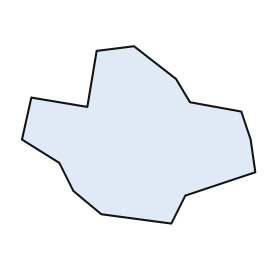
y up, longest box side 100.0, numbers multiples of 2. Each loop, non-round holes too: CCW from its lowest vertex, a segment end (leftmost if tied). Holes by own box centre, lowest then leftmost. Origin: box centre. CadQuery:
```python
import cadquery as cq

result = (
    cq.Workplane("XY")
    .moveTo(14.0, -38.0)
    .lineTo(20.0, -26.0)
    .lineTo(50.0, -16.0)
    .lineTo(48.0, -2.0)
    .lineTo(44.0, 10.0)
    .lineTo(22.0, 14.0)
    .lineTo(16.0, 24.0)
    .lineTo(-2.0, 38.0)
    .lineTo(-18.0, 36.0)
    .lineTo(-22.0, 12.0)
    .lineTo(-46.0, 16.0)
    .lineTo(-50.0, -2.0)
    .lineTo(-34.0, -12.0)
    .lineTo(-28.0, -24.0)
    .lineTo(-16.0, -34.0)
    .close()
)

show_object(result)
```